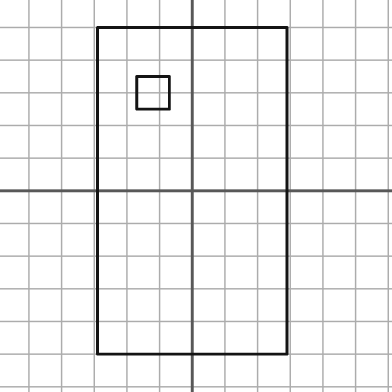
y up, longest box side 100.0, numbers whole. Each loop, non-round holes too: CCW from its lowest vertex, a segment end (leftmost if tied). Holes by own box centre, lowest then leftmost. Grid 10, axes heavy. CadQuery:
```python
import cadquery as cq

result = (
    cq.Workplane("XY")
    .moveTo(-29.0, -50.0)
    .lineTo(29.0, -50.0)
    .lineTo(29.0, 50.0)
    .lineTo(-29.0, 50.0)
    .close()
    .moveTo(-17.0, 25.0)
    .lineTo(-7.0, 25.0)
    .lineTo(-7.0, 35.0)
    .lineTo(-17.0, 35.0)
    .close()
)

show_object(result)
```